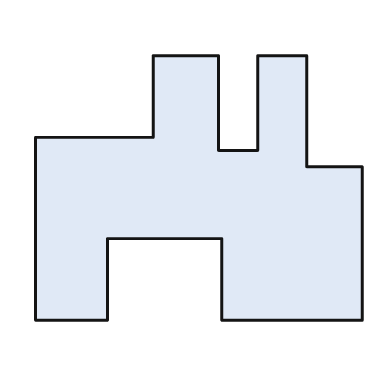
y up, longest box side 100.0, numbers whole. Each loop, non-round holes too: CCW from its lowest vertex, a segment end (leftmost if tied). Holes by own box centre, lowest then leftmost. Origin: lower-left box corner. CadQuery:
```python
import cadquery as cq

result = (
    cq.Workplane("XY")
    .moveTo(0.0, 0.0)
    .lineTo(22.0, 0.0)
    .lineTo(22.0, 25.0)
    .lineTo(57.0, 25.0)
    .lineTo(57.0, 0.0)
    .lineTo(100.0, 0.0)
    .lineTo(100.0, 47.0)
    .lineTo(83.0, 47.0)
    .lineTo(83.0, 81.0)
    .lineTo(68.0, 81.0)
    .lineTo(68.0, 52.0)
    .lineTo(56.0, 52.0)
    .lineTo(56.0, 81.0)
    .lineTo(36.0, 81.0)
    .lineTo(36.0, 56.0)
    .lineTo(0.0, 56.0)
    .close()
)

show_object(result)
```